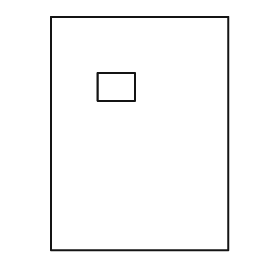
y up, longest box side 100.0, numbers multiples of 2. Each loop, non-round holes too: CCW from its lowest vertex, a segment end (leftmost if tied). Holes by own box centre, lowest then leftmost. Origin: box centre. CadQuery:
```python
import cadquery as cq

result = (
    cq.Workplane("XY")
    .moveTo(-38.0, -50.0)
    .lineTo(38.0, -50.0)
    .lineTo(38.0, 50.0)
    .lineTo(-38.0, 50.0)
    .close()
    .moveTo(-18.0, 14.0)
    .lineTo(-2.0, 14.0)
    .lineTo(-2.0, 26.0)
    .lineTo(-18.0, 26.0)
    .close()
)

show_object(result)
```